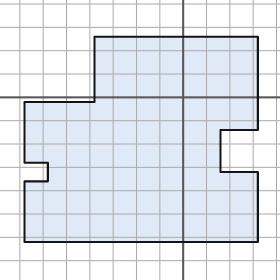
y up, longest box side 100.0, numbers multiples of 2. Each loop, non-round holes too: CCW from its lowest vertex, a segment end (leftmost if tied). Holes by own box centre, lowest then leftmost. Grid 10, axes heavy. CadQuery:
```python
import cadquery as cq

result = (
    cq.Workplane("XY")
    .moveTo(-68.0, -62.0)
    .lineTo(32.0, -62.0)
    .lineTo(32.0, -32.0)
    .lineTo(16.0, -32.0)
    .lineTo(16.0, -14.0)
    .lineTo(32.0, -14.0)
    .lineTo(32.0, 26.0)
    .lineTo(-38.0, 26.0)
    .lineTo(-38.0, -2.0)
    .lineTo(-68.0, -2.0)
    .lineTo(-68.0, -28.0)
    .lineTo(-58.0, -28.0)
    .lineTo(-58.0, -36.0)
    .lineTo(-68.0, -36.0)
    .close()
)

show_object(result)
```